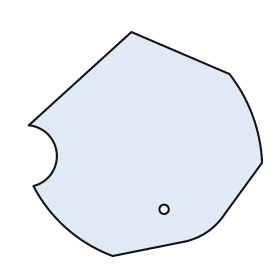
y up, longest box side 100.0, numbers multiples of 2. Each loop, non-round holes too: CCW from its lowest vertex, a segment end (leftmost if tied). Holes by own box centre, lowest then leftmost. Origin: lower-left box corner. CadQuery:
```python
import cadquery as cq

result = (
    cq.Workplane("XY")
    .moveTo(36.0, 0.0)
    .lineTo(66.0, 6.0)
    .threePointArc((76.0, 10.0), (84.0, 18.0))
    .lineTo(100.0, 40.0)
    .threePointArc((96.0, 60.0), (86.0, 78.0))
    .lineTo(44.0, 96.0)
    .lineTo(0.0, 56.0)
    .threePointArc((12.0, 44.0), (2.0, 30.0))
    .threePointArc((16.0, 12.0), (36.0, 0.0))
    .close()
    .moveTo(58.0, 20.0)
    .circle(2.0)
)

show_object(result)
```